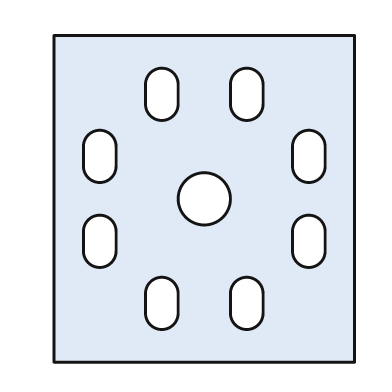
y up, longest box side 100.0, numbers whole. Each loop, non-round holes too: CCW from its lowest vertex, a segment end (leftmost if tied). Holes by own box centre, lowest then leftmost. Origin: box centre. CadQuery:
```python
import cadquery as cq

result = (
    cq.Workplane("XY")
    .moveTo(-46.0, -50.0)
    .lineTo(46.0, -50.0)
    .lineTo(46.0, 50.0)
    .lineTo(-46.0, 50.0)
    .close()
    .moveTo(-18.0, -35.0)
    .threePointArc((-13.0, -40.0), (-8.0, -35.0))
    .lineTo(-8.0, -29.0)
    .threePointArc((-13.0, -24.0), (-18.0, -29.0))
    .close()
    .moveTo(8.0, -35.0)
    .threePointArc((13.0, -40.0), (18.0, -35.0))
    .lineTo(18.0, -29.0)
    .threePointArc((13.0, -24.0), (8.0, -29.0))
    .close()
    .moveTo(-37.0, -16.0)
    .threePointArc((-32.0, -21.0), (-27.0, -16.0))
    .lineTo(-27.0, -10.0)
    .threePointArc((-32.0, -5.0), (-37.0, -10.0))
    .close()
    .moveTo(27.0, -16.0)
    .threePointArc((32.0, -21.0), (37.0, -16.0))
    .lineTo(37.0, -10.0)
    .threePointArc((32.0, -5.0), (27.0, -10.0))
    .close()
    .moveTo(0.0, 0.0)
    .circle(8.0)
    .moveTo(-37.0, 10.0)
    .threePointArc((-32.0, 5.0), (-27.0, 10.0))
    .lineTo(-27.0, 16.0)
    .threePointArc((-32.0, 21.0), (-37.0, 16.0))
    .close()
    .moveTo(27.0, 10.0)
    .threePointArc((32.0, 5.0), (37.0, 10.0))
    .lineTo(37.0, 16.0)
    .threePointArc((32.0, 21.0), (27.0, 16.0))
    .close()
    .moveTo(-18.0, 29.0)
    .threePointArc((-13.0, 24.0), (-8.0, 29.0))
    .lineTo(-8.0, 35.0)
    .threePointArc((-13.0, 40.0), (-18.0, 35.0))
    .close()
    .moveTo(8.0, 29.0)
    .threePointArc((13.0, 24.0), (18.0, 29.0))
    .lineTo(18.0, 35.0)
    .threePointArc((13.0, 40.0), (8.0, 35.0))
    .close()
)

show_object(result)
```